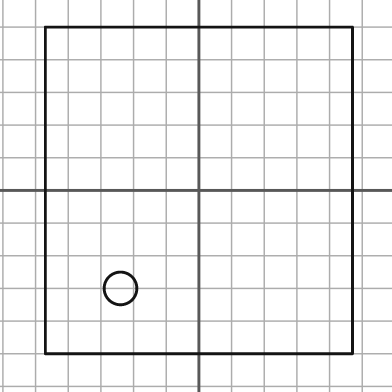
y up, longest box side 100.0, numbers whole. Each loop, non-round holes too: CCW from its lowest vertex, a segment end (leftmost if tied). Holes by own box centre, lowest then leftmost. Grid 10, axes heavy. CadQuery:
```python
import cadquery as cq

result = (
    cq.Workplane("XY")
    .moveTo(-47.0, -50.0)
    .lineTo(47.0, -50.0)
    .lineTo(47.0, 50.0)
    .lineTo(-47.0, 50.0)
    .close()
    .moveTo(-24.0, -30.0)
    .circle(5.0)
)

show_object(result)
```